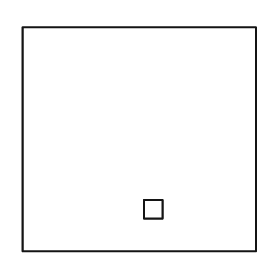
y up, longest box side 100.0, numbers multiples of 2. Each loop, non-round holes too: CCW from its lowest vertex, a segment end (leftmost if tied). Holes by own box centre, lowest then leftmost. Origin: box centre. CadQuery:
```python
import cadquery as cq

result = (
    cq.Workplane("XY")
    .moveTo(-50.0, -48.0)
    .lineTo(50.0, -48.0)
    .lineTo(50.0, 48.0)
    .lineTo(-50.0, 48.0)
    .close()
    .moveTo(2.0, -34.0)
    .lineTo(10.0, -34.0)
    .lineTo(10.0, -26.0)
    .lineTo(2.0, -26.0)
    .close()
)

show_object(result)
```